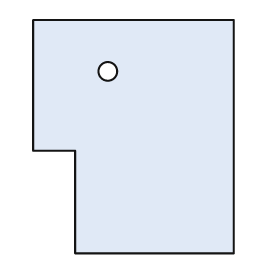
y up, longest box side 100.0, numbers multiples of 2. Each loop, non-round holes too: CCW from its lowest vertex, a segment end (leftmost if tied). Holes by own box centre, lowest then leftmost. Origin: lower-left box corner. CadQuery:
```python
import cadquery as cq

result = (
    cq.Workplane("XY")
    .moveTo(18.0, 0.0)
    .lineTo(86.0, 0.0)
    .lineTo(86.0, 100.0)
    .lineTo(0.0, 100.0)
    .lineTo(0.0, 44.0)
    .lineTo(18.0, 44.0)
    .close()
    .moveTo(32.0, 78.0)
    .circle(4.0)
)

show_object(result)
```